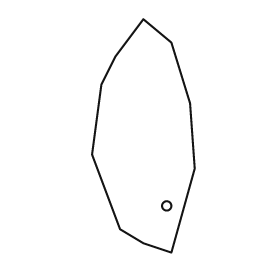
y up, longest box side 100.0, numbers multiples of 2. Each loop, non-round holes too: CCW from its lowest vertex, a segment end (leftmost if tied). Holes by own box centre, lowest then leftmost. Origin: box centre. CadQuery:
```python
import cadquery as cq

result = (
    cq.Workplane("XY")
    .moveTo(12.0, -50.0)
    .lineTo(22.0, -14.0)
    .lineTo(20.0, 14.0)
    .lineTo(12.0, 40.0)
    .lineTo(0.0, 50.0)
    .lineTo(-12.0, 34.0)
    .lineTo(-18.0, 22.0)
    .lineTo(-22.0, -8.0)
    .lineTo(-10.0, -40.0)
    .lineTo(0.0, -46.0)
    .close()
    .moveTo(10.0, -30.0)
    .circle(2.0)
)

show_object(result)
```